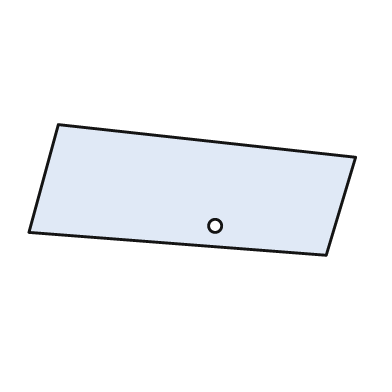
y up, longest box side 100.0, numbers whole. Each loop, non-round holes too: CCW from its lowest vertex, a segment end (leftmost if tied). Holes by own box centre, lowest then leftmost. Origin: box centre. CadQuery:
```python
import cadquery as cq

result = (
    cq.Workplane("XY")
    .moveTo(41.0, -20.0)
    .lineTo(50.0, 10.0)
    .lineTo(-41.0, 20.0)
    .lineTo(-50.0, -13.0)
    .close()
    .moveTo(7.0, -11.0)
    .circle(2.0)
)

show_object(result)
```